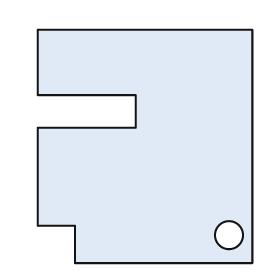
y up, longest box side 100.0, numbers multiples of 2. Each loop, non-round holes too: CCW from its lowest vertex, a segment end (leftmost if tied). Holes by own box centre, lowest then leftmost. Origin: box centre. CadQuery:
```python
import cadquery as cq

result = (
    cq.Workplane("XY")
    .moveTo(-30.0, -50.0)
    .lineTo(46.0, -50.0)
    .lineTo(46.0, 50.0)
    .lineTo(-46.0, 50.0)
    .lineTo(-46.0, 22.0)
    .lineTo(-4.0, 22.0)
    .lineTo(-4.0, 8.0)
    .lineTo(-46.0, 8.0)
    .lineTo(-46.0, -34.0)
    .lineTo(-30.0, -34.0)
    .close()
    .moveTo(36.0, -38.0)
    .circle(6.0)
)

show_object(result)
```